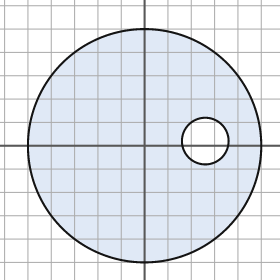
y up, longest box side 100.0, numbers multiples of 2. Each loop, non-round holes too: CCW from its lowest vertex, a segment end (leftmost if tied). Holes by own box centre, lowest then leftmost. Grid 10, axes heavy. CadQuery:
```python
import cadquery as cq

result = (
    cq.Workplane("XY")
    .moveTo(0.0, 0.0)
    .circle(50.0)
    .moveTo(26.0, 2.0)
    .circle(10.0)
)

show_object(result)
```